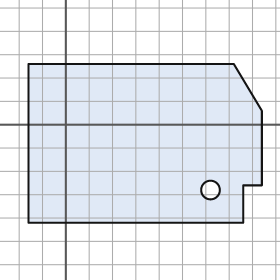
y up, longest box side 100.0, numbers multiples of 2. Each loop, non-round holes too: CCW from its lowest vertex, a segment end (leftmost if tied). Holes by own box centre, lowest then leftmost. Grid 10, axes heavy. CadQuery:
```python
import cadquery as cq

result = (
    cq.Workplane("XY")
    .moveTo(-16.0, -42.0)
    .lineTo(76.0, -42.0)
    .lineTo(76.0, -26.0)
    .lineTo(84.0, -26.0)
    .lineTo(84.0, 6.0)
    .lineTo(72.0, 26.0)
    .lineTo(-16.0, 26.0)
    .close()
    .moveTo(62.0, -28.0)
    .circle(4.0)
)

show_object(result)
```